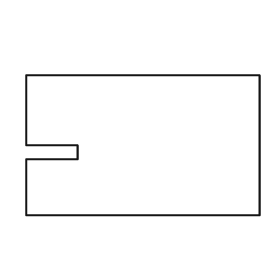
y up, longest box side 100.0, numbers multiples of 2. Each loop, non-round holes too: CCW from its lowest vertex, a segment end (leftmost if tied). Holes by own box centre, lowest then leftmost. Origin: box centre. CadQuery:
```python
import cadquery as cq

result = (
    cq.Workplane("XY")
    .moveTo(-50.0, -30.0)
    .lineTo(50.0, -30.0)
    .lineTo(50.0, 30.0)
    .lineTo(-50.0, 30.0)
    .lineTo(-50.0, 0.0)
    .lineTo(-28.0, 0.0)
    .lineTo(-28.0, -6.0)
    .lineTo(-50.0, -6.0)
    .close()
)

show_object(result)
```